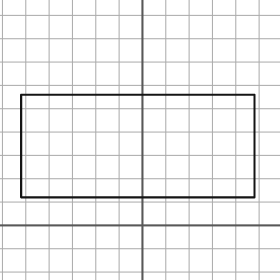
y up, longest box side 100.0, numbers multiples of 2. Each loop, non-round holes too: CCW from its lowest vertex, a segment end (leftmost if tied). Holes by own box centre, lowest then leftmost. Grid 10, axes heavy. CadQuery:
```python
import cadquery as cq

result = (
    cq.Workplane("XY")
    .moveTo(-52.0, 12.0)
    .lineTo(48.0, 12.0)
    .lineTo(48.0, 56.0)
    .lineTo(-52.0, 56.0)
    .close()
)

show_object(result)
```